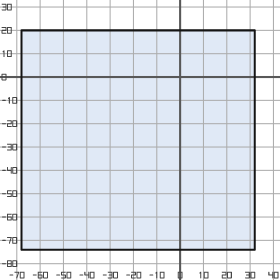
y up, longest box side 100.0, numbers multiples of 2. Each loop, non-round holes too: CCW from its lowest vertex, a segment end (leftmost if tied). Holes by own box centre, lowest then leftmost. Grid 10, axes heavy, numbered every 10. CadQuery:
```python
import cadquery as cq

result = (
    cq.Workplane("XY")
    .moveTo(-68.0, -74.0)
    .lineTo(32.0, -74.0)
    .lineTo(32.0, 20.0)
    .lineTo(-68.0, 20.0)
    .close()
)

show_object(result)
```